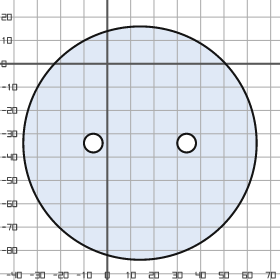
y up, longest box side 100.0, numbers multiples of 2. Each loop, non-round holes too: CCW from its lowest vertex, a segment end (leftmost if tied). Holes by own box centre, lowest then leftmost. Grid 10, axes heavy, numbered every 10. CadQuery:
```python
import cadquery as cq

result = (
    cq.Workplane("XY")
    .moveTo(14.0, -34.0)
    .circle(50.0)
    .moveTo(-6.0, -34.0)
    .circle(4.0)
    .moveTo(34.0, -34.0)
    .circle(4.0)
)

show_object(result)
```